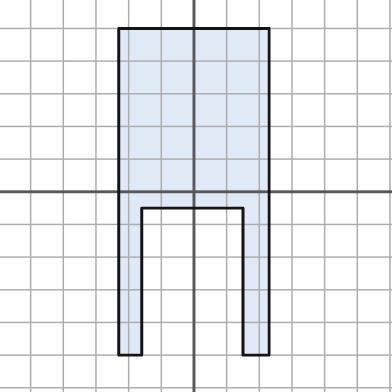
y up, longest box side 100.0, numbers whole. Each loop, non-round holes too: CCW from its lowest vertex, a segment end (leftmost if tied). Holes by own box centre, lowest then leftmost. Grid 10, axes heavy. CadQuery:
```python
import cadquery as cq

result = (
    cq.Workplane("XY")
    .moveTo(-23.0, -50.0)
    .lineTo(-16.0, -50.0)
    .lineTo(-16.0, -5.0)
    .lineTo(15.0, -5.0)
    .lineTo(15.0, -50.0)
    .lineTo(23.0, -50.0)
    .lineTo(23.0, 50.0)
    .lineTo(-23.0, 50.0)
    .close()
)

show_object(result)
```